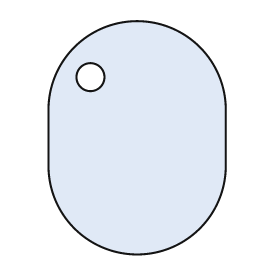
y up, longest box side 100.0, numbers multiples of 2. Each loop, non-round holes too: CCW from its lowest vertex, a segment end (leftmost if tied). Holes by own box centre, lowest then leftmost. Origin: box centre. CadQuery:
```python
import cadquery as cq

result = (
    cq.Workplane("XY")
    .moveTo(-38.0, -12.0)
    .threePointArc((0.0, -50.0), (38.0, -12.0))
    .lineTo(38.0, 12.0)
    .threePointArc((0.0, 50.0), (-38.0, 12.0))
    .close()
    .moveTo(-20.0, 26.0)
    .circle(6.0)
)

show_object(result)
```